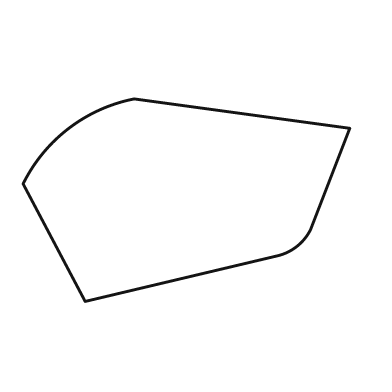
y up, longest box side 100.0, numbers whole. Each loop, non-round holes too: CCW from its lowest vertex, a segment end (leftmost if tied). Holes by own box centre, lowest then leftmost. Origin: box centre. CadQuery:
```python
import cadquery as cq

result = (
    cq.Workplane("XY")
    .moveTo(-31.0, -31.0)
    .lineTo(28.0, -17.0)
    .threePointArc((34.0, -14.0), (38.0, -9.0))
    .lineTo(50.0, 22.0)
    .lineTo(-16.0, 31.0)
    .threePointArc((-36.0, 22.0), (-50.0, 5.0))
    .close()
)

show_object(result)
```